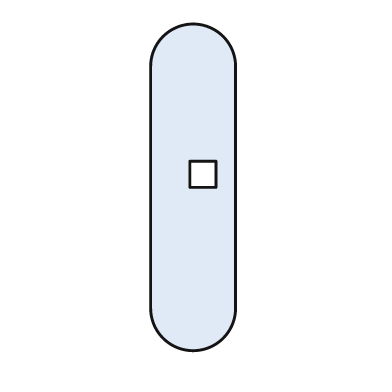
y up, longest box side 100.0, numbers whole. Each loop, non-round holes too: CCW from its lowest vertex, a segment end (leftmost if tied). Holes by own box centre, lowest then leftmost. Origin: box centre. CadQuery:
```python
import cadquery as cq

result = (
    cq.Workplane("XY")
    .moveTo(-13.0, -37.0)
    .threePointArc((0.0, -50.0), (13.0, -37.0))
    .lineTo(13.0, 37.0)
    .threePointArc((0.0, 50.0), (-13.0, 37.0))
    .close()
    .moveTo(-1.0, 0.0)
    .lineTo(7.0, 0.0)
    .lineTo(7.0, 8.0)
    .lineTo(-1.0, 8.0)
    .close()
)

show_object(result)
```